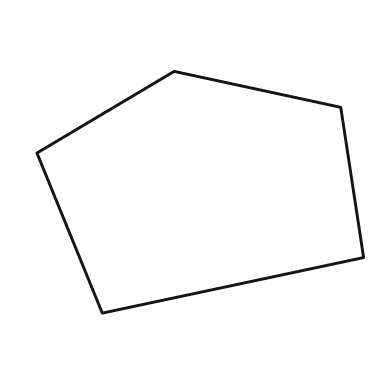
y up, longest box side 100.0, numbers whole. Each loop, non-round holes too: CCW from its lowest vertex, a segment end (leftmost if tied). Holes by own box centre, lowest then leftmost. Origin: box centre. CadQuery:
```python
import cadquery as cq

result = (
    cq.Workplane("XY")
    .moveTo(-30.0, -37.0)
    .lineTo(50.0, -20.0)
    .lineTo(43.0, 26.0)
    .lineTo(-8.0, 37.0)
    .lineTo(-50.0, 12.0)
    .close()
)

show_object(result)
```